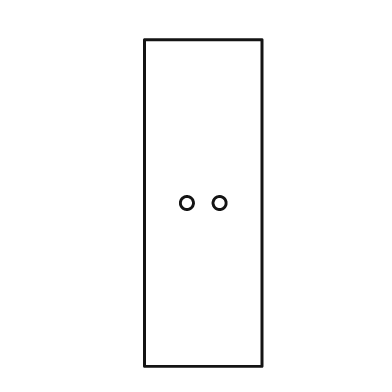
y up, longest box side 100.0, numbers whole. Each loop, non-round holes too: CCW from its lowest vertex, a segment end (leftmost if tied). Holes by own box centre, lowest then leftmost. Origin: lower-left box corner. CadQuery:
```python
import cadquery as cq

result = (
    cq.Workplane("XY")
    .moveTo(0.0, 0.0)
    .lineTo(36.0, 0.0)
    .lineTo(36.0, 100.0)
    .lineTo(0.0, 100.0)
    .close()
    .moveTo(13.0, 50.0)
    .circle(2.0)
    .moveTo(23.0, 50.0)
    .circle(2.0)
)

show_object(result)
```